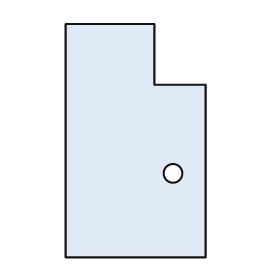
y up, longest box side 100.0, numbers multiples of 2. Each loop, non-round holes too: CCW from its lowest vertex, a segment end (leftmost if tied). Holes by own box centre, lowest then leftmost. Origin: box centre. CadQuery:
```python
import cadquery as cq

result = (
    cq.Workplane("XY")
    .moveTo(-30.0, -50.0)
    .lineTo(30.0, -50.0)
    .lineTo(30.0, 24.0)
    .lineTo(8.0, 24.0)
    .lineTo(8.0, 50.0)
    .lineTo(-30.0, 50.0)
    .close()
    .moveTo(16.0, -14.0)
    .circle(4.0)
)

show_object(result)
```